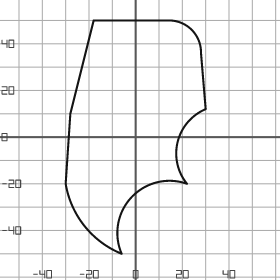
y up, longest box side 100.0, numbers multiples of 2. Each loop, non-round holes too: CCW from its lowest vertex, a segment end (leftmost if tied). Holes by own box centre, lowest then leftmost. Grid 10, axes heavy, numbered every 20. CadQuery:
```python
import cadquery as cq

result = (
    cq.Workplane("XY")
    .moveTo(-6.0, -50.0)
    .threePointArc((-2.0, -26.0), (22.0, -20.0))
    .threePointArc((18.0, -2.0), (30.0, 12.0))
    .lineTo(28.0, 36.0)
    .threePointArc((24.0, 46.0), (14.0, 50.0))
    .lineTo(-18.0, 50.0)
    .lineTo(-28.0, 10.0)
    .lineTo(-30.0, -20.0)
    .threePointArc((-22.0, -38.0), (-6.0, -50.0))
    .close()
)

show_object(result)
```